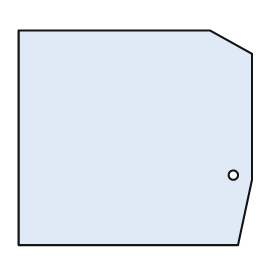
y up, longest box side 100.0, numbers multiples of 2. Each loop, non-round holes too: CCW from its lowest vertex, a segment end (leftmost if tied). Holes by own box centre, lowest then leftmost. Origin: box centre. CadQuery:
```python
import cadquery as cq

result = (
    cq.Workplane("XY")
    .moveTo(-50.0, -46.0)
    .lineTo(44.0, -46.0)
    .lineTo(50.0, -18.0)
    .lineTo(50.0, 36.0)
    .lineTo(32.0, 46.0)
    .lineTo(-50.0, 46.0)
    .close()
    .moveTo(42.0, -16.0)
    .circle(2.0)
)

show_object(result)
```